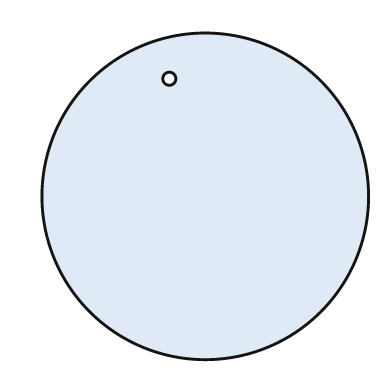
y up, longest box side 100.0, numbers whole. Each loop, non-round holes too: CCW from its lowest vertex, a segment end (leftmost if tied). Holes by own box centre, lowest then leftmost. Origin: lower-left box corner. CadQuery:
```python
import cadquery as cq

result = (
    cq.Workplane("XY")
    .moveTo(50.0, 50.0)
    .circle(50.0)
    .moveTo(39.0, 86.0)
    .circle(2.0)
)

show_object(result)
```